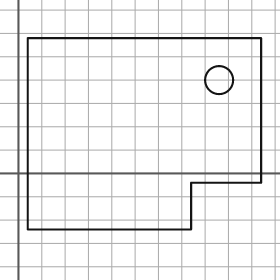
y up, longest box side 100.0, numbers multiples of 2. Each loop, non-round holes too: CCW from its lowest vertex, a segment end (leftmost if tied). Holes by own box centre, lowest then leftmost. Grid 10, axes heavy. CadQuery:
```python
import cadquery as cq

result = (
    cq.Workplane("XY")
    .moveTo(4.0, -24.0)
    .lineTo(74.0, -24.0)
    .lineTo(74.0, -4.0)
    .lineTo(104.0, -4.0)
    .lineTo(104.0, 58.0)
    .lineTo(4.0, 58.0)
    .close()
    .moveTo(86.0, 40.0)
    .circle(6.0)
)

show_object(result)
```